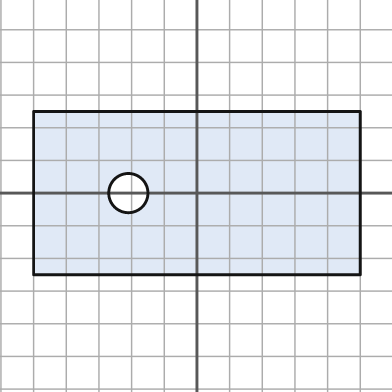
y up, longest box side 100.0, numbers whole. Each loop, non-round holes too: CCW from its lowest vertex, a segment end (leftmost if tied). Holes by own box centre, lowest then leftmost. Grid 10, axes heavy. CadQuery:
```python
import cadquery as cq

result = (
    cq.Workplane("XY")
    .moveTo(-50.0, -25.0)
    .lineTo(50.0, -25.0)
    .lineTo(50.0, 25.0)
    .lineTo(-50.0, 25.0)
    .close()
    .moveTo(-21.0, 0.0)
    .circle(6.0)
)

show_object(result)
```